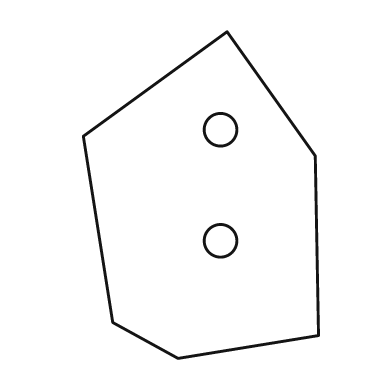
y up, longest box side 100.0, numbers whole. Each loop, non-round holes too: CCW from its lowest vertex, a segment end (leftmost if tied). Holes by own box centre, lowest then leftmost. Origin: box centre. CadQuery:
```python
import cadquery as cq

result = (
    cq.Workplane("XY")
    .moveTo(-7.0, -50.0)
    .lineTo(36.0, -43.0)
    .lineTo(35.0, 12.0)
    .lineTo(8.0, 50.0)
    .lineTo(-36.0, 18.0)
    .lineTo(-27.0, -39.0)
    .close()
    .moveTo(6.0, -14.0)
    .circle(5.0)
    .moveTo(6.0, 20.0)
    .circle(5.0)
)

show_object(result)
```